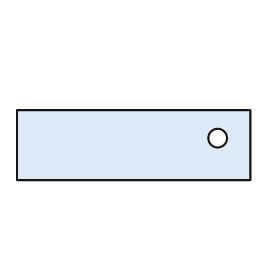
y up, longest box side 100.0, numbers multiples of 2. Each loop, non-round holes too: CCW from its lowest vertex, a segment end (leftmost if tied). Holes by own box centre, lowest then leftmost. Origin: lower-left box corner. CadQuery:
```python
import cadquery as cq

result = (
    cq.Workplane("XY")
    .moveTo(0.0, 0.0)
    .lineTo(100.0, 0.0)
    .lineTo(100.0, 30.0)
    .lineTo(0.0, 30.0)
    .close()
    .moveTo(86.0, 18.0)
    .circle(4.0)
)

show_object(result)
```